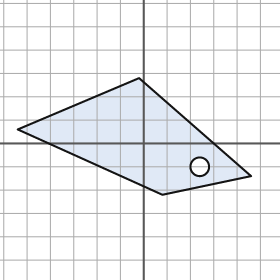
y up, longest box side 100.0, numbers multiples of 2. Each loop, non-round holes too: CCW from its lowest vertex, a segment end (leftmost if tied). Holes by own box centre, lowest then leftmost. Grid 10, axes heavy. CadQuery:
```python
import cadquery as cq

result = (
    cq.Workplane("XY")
    .moveTo(8.0, -22.0)
    .lineTo(46.0, -14.0)
    .lineTo(-2.0, 28.0)
    .lineTo(-54.0, 6.0)
    .close()
    .moveTo(24.0, -10.0)
    .circle(4.0)
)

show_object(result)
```